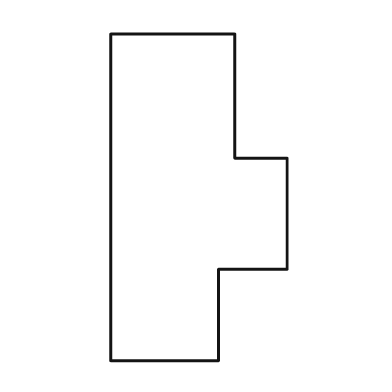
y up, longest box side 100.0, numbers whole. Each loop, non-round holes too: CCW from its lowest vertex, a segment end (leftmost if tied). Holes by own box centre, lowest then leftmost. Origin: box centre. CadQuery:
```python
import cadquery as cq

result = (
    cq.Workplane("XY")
    .moveTo(-27.0, -50.0)
    .lineTo(6.0, -50.0)
    .lineTo(6.0, -22.0)
    .lineTo(27.0, -22.0)
    .lineTo(27.0, 12.0)
    .lineTo(11.0, 12.0)
    .lineTo(11.0, 50.0)
    .lineTo(-27.0, 50.0)
    .close()
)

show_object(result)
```